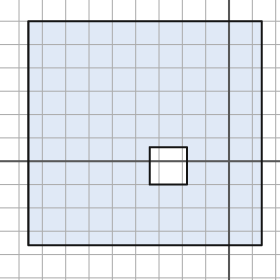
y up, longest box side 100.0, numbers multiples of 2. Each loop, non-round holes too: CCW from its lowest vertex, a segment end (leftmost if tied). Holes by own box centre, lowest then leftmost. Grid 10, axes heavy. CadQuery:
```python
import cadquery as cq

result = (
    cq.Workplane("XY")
    .moveTo(-86.0, -36.0)
    .lineTo(14.0, -36.0)
    .lineTo(14.0, 60.0)
    .lineTo(-86.0, 60.0)
    .close()
    .moveTo(-34.0, -10.0)
    .lineTo(-18.0, -10.0)
    .lineTo(-18.0, 6.0)
    .lineTo(-34.0, 6.0)
    .close()
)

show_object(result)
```